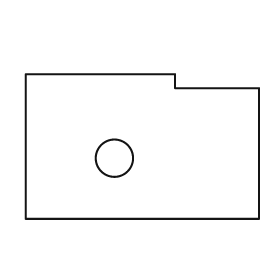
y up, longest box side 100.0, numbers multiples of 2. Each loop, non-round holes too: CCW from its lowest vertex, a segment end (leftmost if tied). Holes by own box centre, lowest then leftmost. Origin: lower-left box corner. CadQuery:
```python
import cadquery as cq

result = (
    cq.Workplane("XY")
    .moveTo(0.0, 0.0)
    .lineTo(100.0, 0.0)
    .lineTo(100.0, 56.0)
    .lineTo(64.0, 56.0)
    .lineTo(64.0, 62.0)
    .lineTo(0.0, 62.0)
    .close()
    .moveTo(38.0, 26.0)
    .circle(8.0)
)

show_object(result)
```